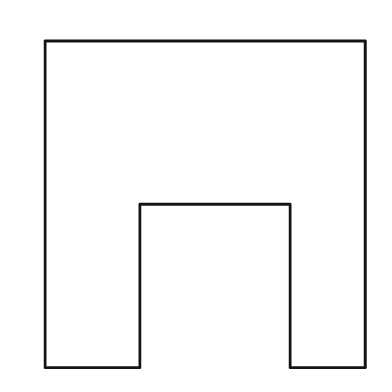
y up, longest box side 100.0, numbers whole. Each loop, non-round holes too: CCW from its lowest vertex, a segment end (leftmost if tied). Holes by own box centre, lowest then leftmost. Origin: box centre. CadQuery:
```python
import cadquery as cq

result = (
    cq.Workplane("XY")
    .moveTo(-49.0, -50.0)
    .lineTo(-20.0, -50.0)
    .lineTo(-20.0, 0.0)
    .lineTo(26.0, 0.0)
    .lineTo(26.0, -50.0)
    .lineTo(49.0, -50.0)
    .lineTo(49.0, 50.0)
    .lineTo(-49.0, 50.0)
    .close()
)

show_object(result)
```